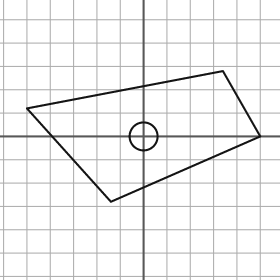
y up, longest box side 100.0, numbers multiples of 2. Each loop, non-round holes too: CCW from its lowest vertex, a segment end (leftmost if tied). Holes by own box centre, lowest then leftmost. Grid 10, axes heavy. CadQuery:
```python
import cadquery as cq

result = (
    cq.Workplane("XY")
    .moveTo(-14.0, -28.0)
    .lineTo(50.0, 0.0)
    .lineTo(34.0, 28.0)
    .lineTo(-50.0, 12.0)
    .close()
    .moveTo(0.0, 0.0)
    .circle(6.0)
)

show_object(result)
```